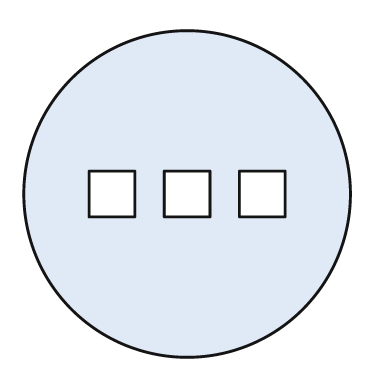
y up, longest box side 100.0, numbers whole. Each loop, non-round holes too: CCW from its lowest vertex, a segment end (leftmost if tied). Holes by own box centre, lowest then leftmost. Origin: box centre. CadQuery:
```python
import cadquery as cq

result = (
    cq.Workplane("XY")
    .moveTo(0.0, 0.0)
    .circle(50.0)
    .moveTo(-30.0, -7.0)
    .lineTo(-16.0, -7.0)
    .lineTo(-16.0, 7.0)
    .lineTo(-30.0, 7.0)
    .close()
    .moveTo(-7.0, -7.0)
    .lineTo(7.0, -7.0)
    .lineTo(7.0, 7.0)
    .lineTo(-7.0, 7.0)
    .close()
    .moveTo(16.0, -7.0)
    .lineTo(30.0, -7.0)
    .lineTo(30.0, 7.0)
    .lineTo(16.0, 7.0)
    .close()
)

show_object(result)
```